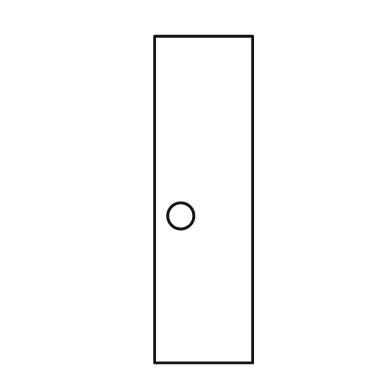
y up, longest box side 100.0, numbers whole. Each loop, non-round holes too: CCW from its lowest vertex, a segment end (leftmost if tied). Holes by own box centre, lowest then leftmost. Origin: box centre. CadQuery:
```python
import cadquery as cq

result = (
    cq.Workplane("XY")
    .moveTo(-15.0, -50.0)
    .lineTo(15.0, -50.0)
    .lineTo(15.0, 50.0)
    .lineTo(-15.0, 50.0)
    .close()
    .moveTo(-7.0, -5.0)
    .circle(4.0)
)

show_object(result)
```